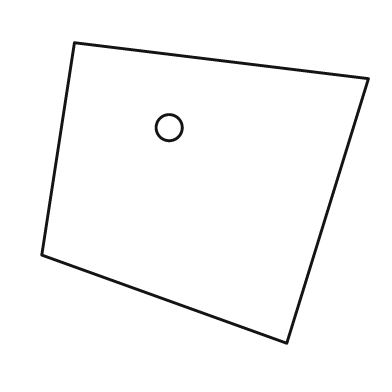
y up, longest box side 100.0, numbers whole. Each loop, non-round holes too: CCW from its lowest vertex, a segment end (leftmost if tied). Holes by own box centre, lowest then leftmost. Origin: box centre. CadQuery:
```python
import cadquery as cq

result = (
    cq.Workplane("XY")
    .moveTo(25.0, -46.0)
    .lineTo(50.0, 35.0)
    .lineTo(-40.0, 46.0)
    .lineTo(-50.0, -19.0)
    .close()
    .moveTo(-11.0, 20.0)
    .circle(4.0)
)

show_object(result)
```